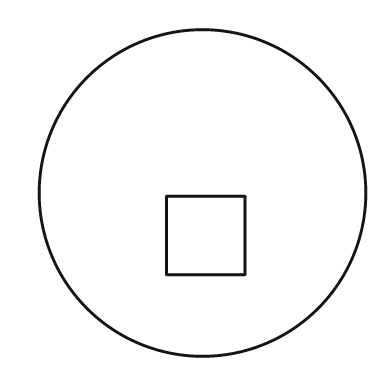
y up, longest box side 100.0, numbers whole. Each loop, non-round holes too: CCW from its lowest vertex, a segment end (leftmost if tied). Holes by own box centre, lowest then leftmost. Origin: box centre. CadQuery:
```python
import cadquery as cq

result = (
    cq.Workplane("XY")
    .moveTo(0.0, 0.0)
    .circle(50.0)
    .moveTo(-11.0, -25.0)
    .lineTo(13.0, -25.0)
    .lineTo(13.0, -1.0)
    .lineTo(-11.0, -1.0)
    .close()
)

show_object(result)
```